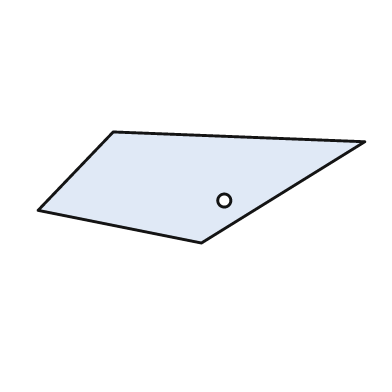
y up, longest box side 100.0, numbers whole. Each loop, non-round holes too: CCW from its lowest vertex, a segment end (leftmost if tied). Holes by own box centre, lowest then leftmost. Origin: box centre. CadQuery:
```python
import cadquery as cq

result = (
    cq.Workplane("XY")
    .moveTo(0.0, -17.0)
    .lineTo(50.0, 14.0)
    .lineTo(-27.0, 17.0)
    .lineTo(-50.0, -7.0)
    .close()
    .moveTo(7.0, -4.0)
    .circle(2.0)
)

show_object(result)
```